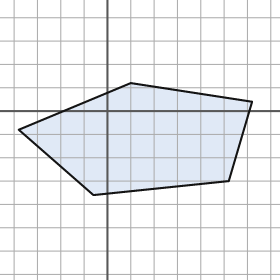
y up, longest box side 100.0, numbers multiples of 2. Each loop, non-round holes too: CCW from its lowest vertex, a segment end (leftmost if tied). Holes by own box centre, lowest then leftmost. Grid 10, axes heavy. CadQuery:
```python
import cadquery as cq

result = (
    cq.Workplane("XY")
    .moveTo(-6.0, -36.0)
    .lineTo(52.0, -30.0)
    .lineTo(62.0, 4.0)
    .lineTo(10.0, 12.0)
    .lineTo(-38.0, -8.0)
    .close()
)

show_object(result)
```